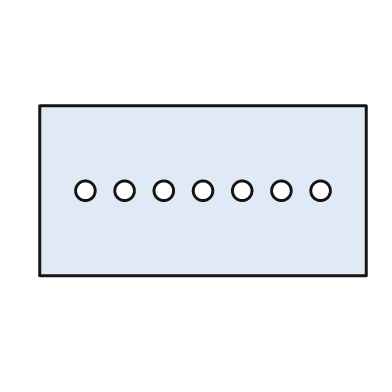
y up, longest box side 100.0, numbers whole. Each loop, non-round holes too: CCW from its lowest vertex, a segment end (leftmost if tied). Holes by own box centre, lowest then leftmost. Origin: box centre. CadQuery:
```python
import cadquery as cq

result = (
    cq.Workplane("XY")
    .moveTo(-50.0, -26.0)
    .lineTo(50.0, -26.0)
    .lineTo(50.0, 26.0)
    .lineTo(-50.0, 26.0)
    .close()
    .moveTo(-36.0, 0.0)
    .circle(3.0)
    .moveTo(-24.0, 0.0)
    .circle(3.0)
    .moveTo(-12.0, 0.0)
    .circle(3.0)
    .moveTo(0.0, 0.0)
    .circle(3.0)
    .moveTo(12.0, 0.0)
    .circle(3.0)
    .moveTo(24.0, 0.0)
    .circle(3.0)
    .moveTo(36.0, 0.0)
    .circle(3.0)
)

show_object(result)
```